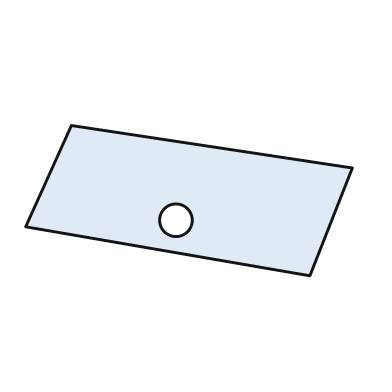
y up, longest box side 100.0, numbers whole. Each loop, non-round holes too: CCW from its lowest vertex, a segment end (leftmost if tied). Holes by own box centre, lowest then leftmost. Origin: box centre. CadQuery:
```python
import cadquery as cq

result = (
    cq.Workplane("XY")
    .moveTo(37.0, -23.0)
    .lineTo(50.0, 10.0)
    .lineTo(-36.0, 23.0)
    .lineTo(-50.0, -8.0)
    .close()
    .moveTo(-4.0, -6.0)
    .circle(5.0)
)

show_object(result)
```